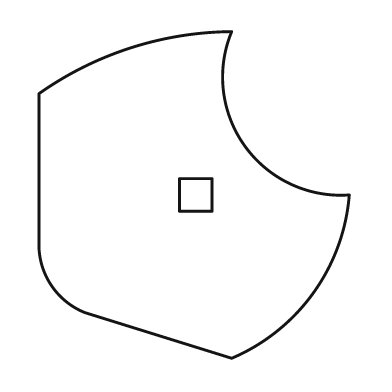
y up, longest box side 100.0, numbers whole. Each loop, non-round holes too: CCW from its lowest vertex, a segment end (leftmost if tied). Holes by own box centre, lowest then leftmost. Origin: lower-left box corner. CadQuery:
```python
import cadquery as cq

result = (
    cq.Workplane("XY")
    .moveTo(59.0, 0.0)
    .threePointArc((84.0, 20.0), (95.0, 50.0))
    .threePointArc((63.0, 65.0), (59.0, 100.0))
    .threePointArc((28.0, 95.0), (0.0, 81.0))
    .lineTo(0.0, 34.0)
    .threePointArc((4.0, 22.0), (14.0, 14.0))
    .close()
    .moveTo(43.0, 45.0)
    .lineTo(53.0, 45.0)
    .lineTo(53.0, 55.0)
    .lineTo(43.0, 55.0)
    .close()
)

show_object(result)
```